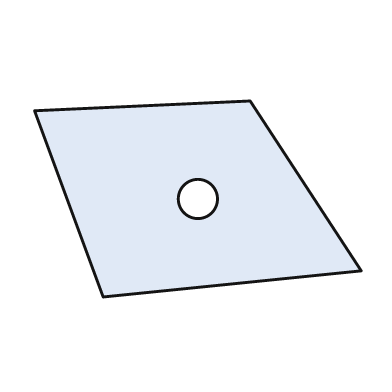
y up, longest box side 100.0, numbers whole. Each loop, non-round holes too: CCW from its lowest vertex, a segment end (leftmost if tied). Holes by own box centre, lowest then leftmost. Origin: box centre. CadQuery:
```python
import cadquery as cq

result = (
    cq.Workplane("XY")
    .moveTo(-29.0, -30.0)
    .lineTo(50.0, -22.0)
    .lineTo(16.0, 30.0)
    .lineTo(-50.0, 27.0)
    .close()
    .moveTo(0.0, 0.0)
    .circle(6.0)
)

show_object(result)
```